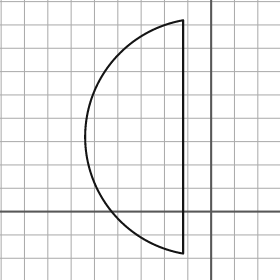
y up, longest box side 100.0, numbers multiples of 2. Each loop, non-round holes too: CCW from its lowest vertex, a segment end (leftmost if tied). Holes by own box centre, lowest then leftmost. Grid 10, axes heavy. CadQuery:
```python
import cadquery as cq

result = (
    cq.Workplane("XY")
    .moveTo(-12.0, -18.0)
    .lineTo(-12.0, 82.0)
    .threePointArc((-54.0, 32.0), (-12.0, -18.0))
    .close()
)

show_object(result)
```